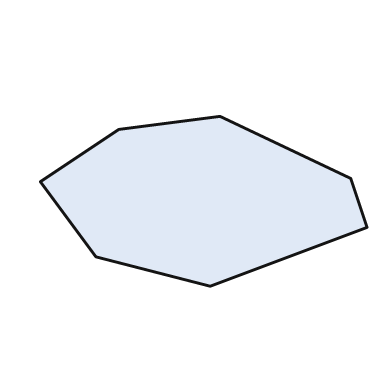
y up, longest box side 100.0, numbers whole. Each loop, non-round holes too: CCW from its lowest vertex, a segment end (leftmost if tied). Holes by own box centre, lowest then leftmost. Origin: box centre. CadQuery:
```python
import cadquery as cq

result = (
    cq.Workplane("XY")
    .moveTo(2.0, -26.0)
    .lineTo(50.0, -8.0)
    .lineTo(45.0, 7.0)
    .lineTo(5.0, 26.0)
    .lineTo(-26.0, 22.0)
    .lineTo(-50.0, 6.0)
    .lineTo(-33.0, -17.0)
    .close()
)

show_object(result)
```